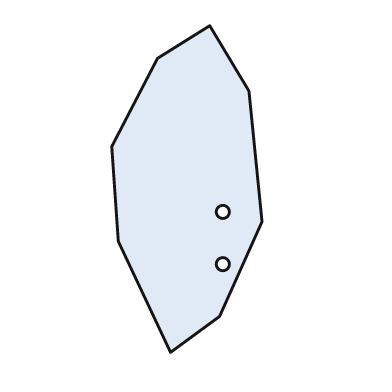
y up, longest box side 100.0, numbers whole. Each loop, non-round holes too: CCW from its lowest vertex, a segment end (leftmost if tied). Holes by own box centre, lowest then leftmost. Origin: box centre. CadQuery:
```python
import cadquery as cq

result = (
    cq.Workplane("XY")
    .moveTo(-5.0, -50.0)
    .lineTo(10.0, -39.0)
    .lineTo(23.0, -10.0)
    .lineTo(19.0, 30.0)
    .lineTo(7.0, 50.0)
    .lineTo(-9.0, 40.0)
    .lineTo(-23.0, 13.0)
    .lineTo(-21.0, -16.0)
    .close()
    .moveTo(11.0, -23.0)
    .circle(2.0)
    .moveTo(11.0, -7.0)
    .circle(2.0)
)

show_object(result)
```